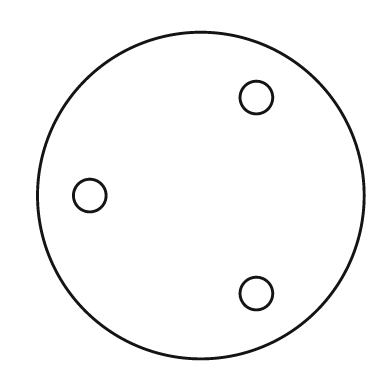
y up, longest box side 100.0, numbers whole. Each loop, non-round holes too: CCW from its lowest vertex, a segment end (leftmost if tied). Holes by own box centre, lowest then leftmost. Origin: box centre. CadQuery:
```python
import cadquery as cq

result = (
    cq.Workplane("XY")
    .moveTo(0.0, 0.0)
    .circle(50.0)
    .moveTo(17.0, -30.0)
    .circle(5.0)
    .moveTo(-34.0, 0.0)
    .circle(5.0)
    .moveTo(17.0, 30.0)
    .circle(5.0)
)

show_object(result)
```